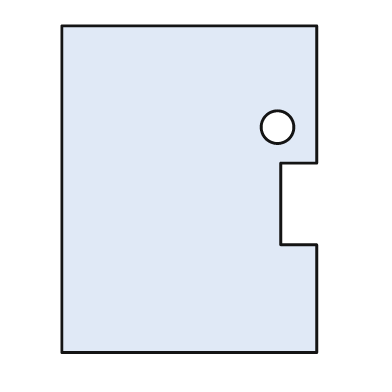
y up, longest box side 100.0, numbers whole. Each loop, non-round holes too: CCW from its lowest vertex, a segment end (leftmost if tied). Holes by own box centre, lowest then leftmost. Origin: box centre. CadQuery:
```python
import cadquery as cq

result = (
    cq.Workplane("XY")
    .moveTo(-39.0, -50.0)
    .lineTo(39.0, -50.0)
    .lineTo(39.0, -17.0)
    .lineTo(28.0, -17.0)
    .lineTo(28.0, 8.0)
    .lineTo(39.0, 8.0)
    .lineTo(39.0, 50.0)
    .lineTo(-39.0, 50.0)
    .close()
    .moveTo(27.0, 19.0)
    .circle(5.0)
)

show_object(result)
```